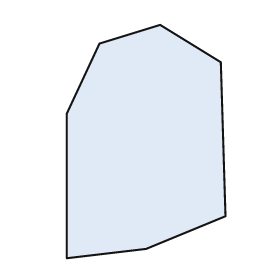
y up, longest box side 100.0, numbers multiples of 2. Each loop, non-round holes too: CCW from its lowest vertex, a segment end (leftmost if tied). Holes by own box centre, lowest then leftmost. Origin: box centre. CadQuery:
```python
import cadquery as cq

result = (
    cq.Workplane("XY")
    .moveTo(-34.0, -50.0)
    .lineTo(0.0, -46.0)
    .lineTo(34.0, -32.0)
    .lineTo(32.0, 34.0)
    .lineTo(6.0, 50.0)
    .lineTo(-20.0, 42.0)
    .lineTo(-34.0, 12.0)
    .close()
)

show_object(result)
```